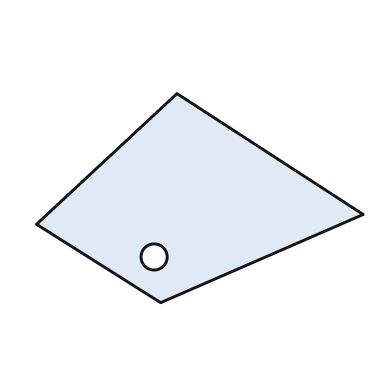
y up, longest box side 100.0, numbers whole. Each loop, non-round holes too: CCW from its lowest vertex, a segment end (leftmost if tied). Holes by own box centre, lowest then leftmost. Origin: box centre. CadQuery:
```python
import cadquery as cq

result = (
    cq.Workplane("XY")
    .moveTo(-12.0, -32.0)
    .lineTo(50.0, -5.0)
    .lineTo(-7.0, 32.0)
    .lineTo(-50.0, -8.0)
    .close()
    .moveTo(-14.0, -18.0)
    .circle(4.0)
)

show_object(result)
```